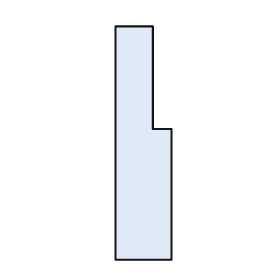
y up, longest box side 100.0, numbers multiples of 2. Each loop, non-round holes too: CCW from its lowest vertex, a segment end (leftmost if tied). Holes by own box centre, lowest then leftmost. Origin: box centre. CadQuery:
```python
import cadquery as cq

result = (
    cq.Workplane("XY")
    .moveTo(-12.0, -50.0)
    .lineTo(12.0, -50.0)
    .lineTo(12.0, 6.0)
    .lineTo(4.0, 6.0)
    .lineTo(4.0, 50.0)
    .lineTo(-12.0, 50.0)
    .close()
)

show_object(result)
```